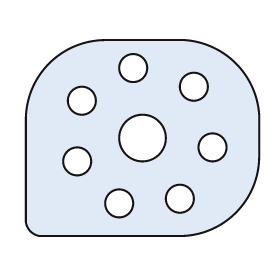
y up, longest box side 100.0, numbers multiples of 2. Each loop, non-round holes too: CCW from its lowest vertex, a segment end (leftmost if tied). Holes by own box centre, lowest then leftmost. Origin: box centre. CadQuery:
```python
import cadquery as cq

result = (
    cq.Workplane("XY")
    .moveTo(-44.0, -42.0)
    .lineTo(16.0, -42.0)
    .threePointArc((40.0, -32.0), (50.0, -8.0))
    .lineTo(50.0, 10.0)
    .threePointArc((40.0, 32.0), (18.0, 42.0))
    .lineTo(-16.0, 42.0)
    .threePointArc((-40.0, 32.0), (-50.0, 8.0))
    .lineTo(-50.0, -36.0)
    .threePointArc((-48.0, -40.0), (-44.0, -42.0))
    .close()
    .moveTo(-10.0, -28.0)
    .circle(6.0)
    .moveTo(16.0, -26.0)
    .circle(6.0)
    .moveTo(-28.0, -10.0)
    .circle(6.0)
    .moveTo(30.0, -4.0)
    .circle(6.0)
    .moveTo(0.0, 0.0)
    .circle(10.0)
    .moveTo(-26.0, 16.0)
    .circle(6.0)
    .moveTo(22.0, 22.0)
    .circle(6.0)
    .moveTo(-4.0, 30.0)
    .circle(6.0)
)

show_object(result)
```